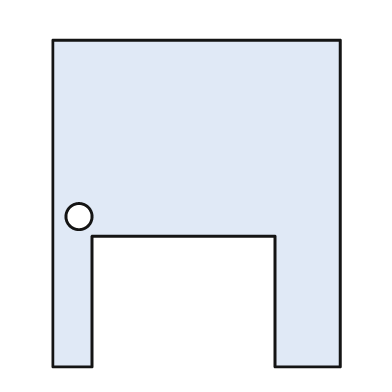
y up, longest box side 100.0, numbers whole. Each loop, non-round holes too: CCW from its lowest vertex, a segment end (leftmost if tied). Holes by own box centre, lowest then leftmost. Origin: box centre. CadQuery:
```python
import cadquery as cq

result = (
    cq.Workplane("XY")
    .moveTo(-44.0, -50.0)
    .lineTo(-32.0, -50.0)
    .lineTo(-32.0, -10.0)
    .lineTo(24.0, -10.0)
    .lineTo(24.0, -50.0)
    .lineTo(44.0, -50.0)
    .lineTo(44.0, 50.0)
    .lineTo(-44.0, 50.0)
    .close()
    .moveTo(-36.0, -4.0)
    .circle(4.0)
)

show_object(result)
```